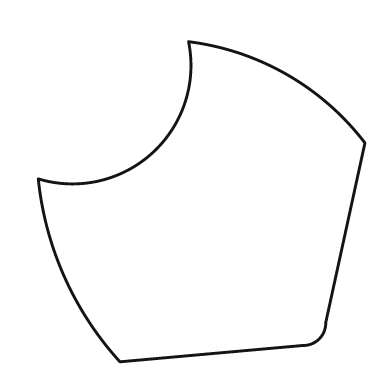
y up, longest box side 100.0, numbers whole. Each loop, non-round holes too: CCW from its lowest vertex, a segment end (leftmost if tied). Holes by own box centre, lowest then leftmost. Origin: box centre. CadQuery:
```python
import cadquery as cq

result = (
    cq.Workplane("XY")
    .moveTo(-25.0, -49.0)
    .lineTo(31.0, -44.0)
    .threePointArc((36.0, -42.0), (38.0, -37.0))
    .lineTo(50.0, 18.0)
    .threePointArc((26.0, 39.0), (-4.0, 49.0))
    .threePointArc((-15.0, 15.0), (-50.0, 7.0))
    .threePointArc((-42.0, -23.0), (-25.0, -49.0))
    .close()
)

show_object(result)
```